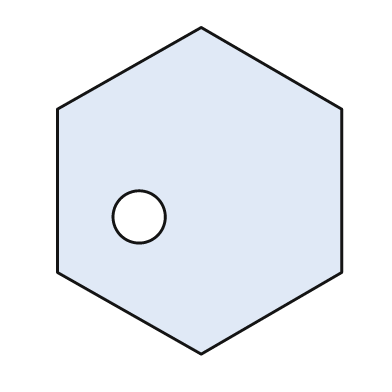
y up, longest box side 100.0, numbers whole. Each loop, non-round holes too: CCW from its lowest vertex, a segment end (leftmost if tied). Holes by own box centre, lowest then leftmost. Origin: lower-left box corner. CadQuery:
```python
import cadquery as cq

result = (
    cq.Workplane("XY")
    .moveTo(44.0, 0.0)
    .lineTo(87.0, 25.0)
    .lineTo(87.0, 75.0)
    .lineTo(44.0, 100.0)
    .lineTo(0.0, 75.0)
    .lineTo(0.0, 25.0)
    .close()
    .moveTo(25.0, 42.0)
    .circle(8.0)
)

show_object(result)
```